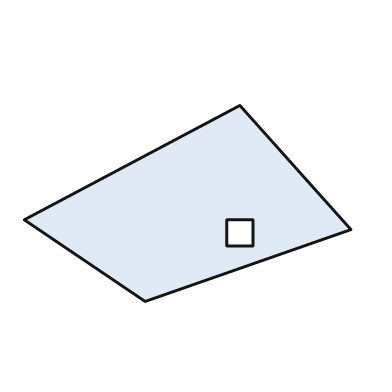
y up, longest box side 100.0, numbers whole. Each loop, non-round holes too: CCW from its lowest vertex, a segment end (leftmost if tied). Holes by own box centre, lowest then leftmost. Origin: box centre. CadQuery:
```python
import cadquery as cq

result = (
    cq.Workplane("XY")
    .moveTo(-13.0, -30.0)
    .lineTo(50.0, -8.0)
    .lineTo(16.0, 30.0)
    .lineTo(-50.0, -5.0)
    .close()
    .moveTo(12.0, -13.0)
    .lineTo(20.0, -13.0)
    .lineTo(20.0, -5.0)
    .lineTo(12.0, -5.0)
    .close()
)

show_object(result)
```